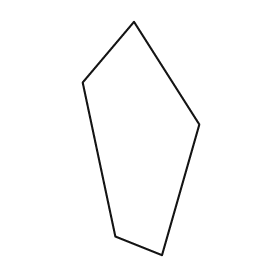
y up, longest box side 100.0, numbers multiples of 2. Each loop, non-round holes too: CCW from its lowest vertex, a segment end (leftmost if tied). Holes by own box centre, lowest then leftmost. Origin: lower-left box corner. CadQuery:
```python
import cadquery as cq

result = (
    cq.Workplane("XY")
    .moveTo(34.0, 0.0)
    .lineTo(50.0, 56.0)
    .lineTo(22.0, 100.0)
    .lineTo(0.0, 74.0)
    .lineTo(14.0, 8.0)
    .close()
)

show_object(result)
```